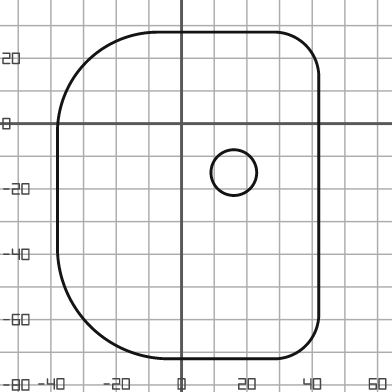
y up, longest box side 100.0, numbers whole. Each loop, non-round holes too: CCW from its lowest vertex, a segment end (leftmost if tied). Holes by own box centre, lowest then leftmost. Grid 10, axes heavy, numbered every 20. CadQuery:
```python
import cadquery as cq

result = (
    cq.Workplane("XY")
    .moveTo(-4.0, -72.0)
    .lineTo(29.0, -72.0)
    .threePointArc((38.0, -68.0), (42.0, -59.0))
    .lineTo(42.0, 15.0)
    .threePointArc((38.0, 24.0), (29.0, 28.0))
    .lineTo(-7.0, 28.0)
    .threePointArc((-29.0, 19.0), (-38.0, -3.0))
    .lineTo(-38.0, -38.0)
    .threePointArc((-28.0, -62.0), (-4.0, -72.0))
    .close()
    .moveTo(16.0, -15.0)
    .circle(7.0)
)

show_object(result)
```